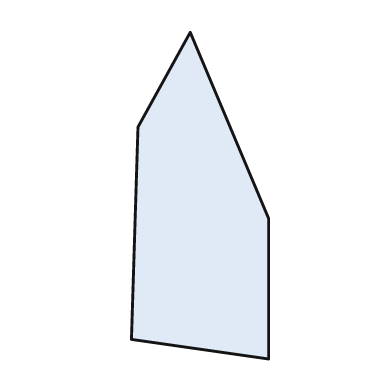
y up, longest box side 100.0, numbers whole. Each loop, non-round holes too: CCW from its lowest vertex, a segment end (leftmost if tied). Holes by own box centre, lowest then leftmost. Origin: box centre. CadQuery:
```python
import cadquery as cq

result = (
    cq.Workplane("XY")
    .moveTo(21.0, -50.0)
    .lineTo(21.0, -7.0)
    .lineTo(-3.0, 50.0)
    .lineTo(-19.0, 21.0)
    .lineTo(-21.0, -44.0)
    .close()
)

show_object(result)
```